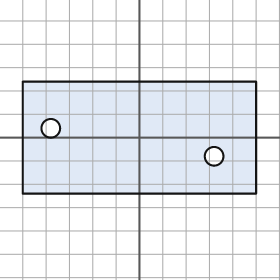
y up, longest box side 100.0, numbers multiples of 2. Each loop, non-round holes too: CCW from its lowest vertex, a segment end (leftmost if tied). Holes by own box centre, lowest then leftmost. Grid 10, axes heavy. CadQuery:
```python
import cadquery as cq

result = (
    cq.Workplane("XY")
    .moveTo(-50.0, -24.0)
    .lineTo(50.0, -24.0)
    .lineTo(50.0, 24.0)
    .lineTo(-50.0, 24.0)
    .close()
    .moveTo(32.0, -8.0)
    .circle(4.0)
    .moveTo(-38.0, 4.0)
    .circle(4.0)
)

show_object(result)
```